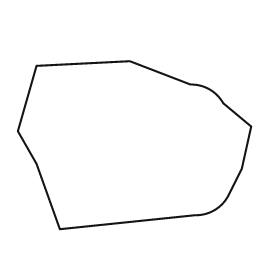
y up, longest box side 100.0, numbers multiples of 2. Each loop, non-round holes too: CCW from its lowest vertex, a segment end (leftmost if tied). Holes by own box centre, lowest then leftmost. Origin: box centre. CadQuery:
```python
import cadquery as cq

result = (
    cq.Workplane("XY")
    .moveTo(-32.0, -36.0)
    .lineTo(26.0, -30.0)
    .threePointArc((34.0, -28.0), (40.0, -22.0))
    .lineTo(46.0, -10.0)
    .lineTo(50.0, 8.0)
    .lineTo(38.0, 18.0)
    .threePointArc((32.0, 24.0), (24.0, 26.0))
    .lineTo(-2.0, 36.0)
    .lineTo(-42.0, 34.0)
    .lineTo(-50.0, 6.0)
    .lineTo(-42.0, -8.0)
    .close()
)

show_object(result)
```